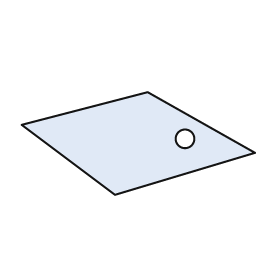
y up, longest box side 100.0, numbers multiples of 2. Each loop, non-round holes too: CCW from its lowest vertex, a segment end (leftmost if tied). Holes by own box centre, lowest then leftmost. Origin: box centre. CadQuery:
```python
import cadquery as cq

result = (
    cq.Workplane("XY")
    .moveTo(-10.0, -22.0)
    .lineTo(50.0, -4.0)
    .lineTo(4.0, 22.0)
    .lineTo(-50.0, 8.0)
    .close()
    .moveTo(20.0, 2.0)
    .circle(4.0)
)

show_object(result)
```